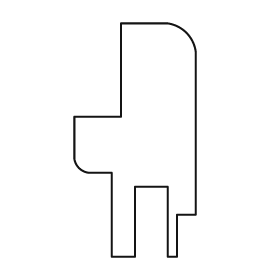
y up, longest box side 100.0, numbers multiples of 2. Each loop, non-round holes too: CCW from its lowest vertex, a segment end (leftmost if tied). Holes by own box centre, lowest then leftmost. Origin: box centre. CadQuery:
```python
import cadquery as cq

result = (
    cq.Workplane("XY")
    .moveTo(-10.0, -50.0)
    .lineTo(0.0, -50.0)
    .lineTo(0.0, -20.0)
    .lineTo(14.0, -20.0)
    .lineTo(14.0, -50.0)
    .lineTo(18.0, -50.0)
    .lineTo(18.0, -32.0)
    .lineTo(26.0, -32.0)
    .lineTo(26.0, 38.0)
    .threePointArc((22.0, 46.0), (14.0, 50.0))
    .lineTo(-6.0, 50.0)
    .lineTo(-6.0, 10.0)
    .lineTo(-26.0, 10.0)
    .lineTo(-26.0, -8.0)
    .threePointArc((-24.0, -12.0), (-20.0, -14.0))
    .lineTo(-10.0, -14.0)
    .close()
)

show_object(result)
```